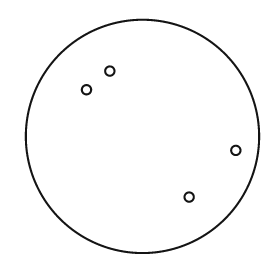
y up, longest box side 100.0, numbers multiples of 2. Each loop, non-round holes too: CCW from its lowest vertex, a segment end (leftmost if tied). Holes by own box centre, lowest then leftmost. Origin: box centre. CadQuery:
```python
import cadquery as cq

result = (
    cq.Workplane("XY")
    .moveTo(0.0, 0.0)
    .circle(50.0)
    .moveTo(20.0, -26.0)
    .circle(2.0)
    .moveTo(40.0, -6.0)
    .circle(2.0)
    .moveTo(-24.0, 20.0)
    .circle(2.0)
    .moveTo(-14.0, 28.0)
    .circle(2.0)
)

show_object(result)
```